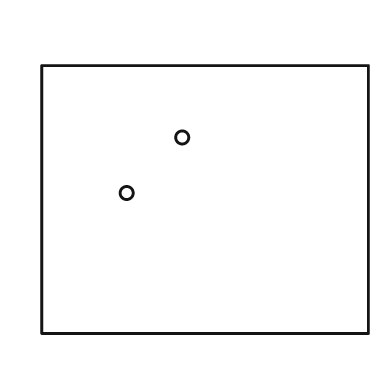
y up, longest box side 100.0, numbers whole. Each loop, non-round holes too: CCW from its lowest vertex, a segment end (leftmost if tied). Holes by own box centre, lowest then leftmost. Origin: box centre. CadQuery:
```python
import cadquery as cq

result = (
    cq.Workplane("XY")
    .moveTo(-50.0, -41.0)
    .lineTo(50.0, -41.0)
    .lineTo(50.0, 41.0)
    .lineTo(-50.0, 41.0)
    .close()
    .moveTo(-24.0, 2.0)
    .circle(2.0)
    .moveTo(-7.0, 19.0)
    .circle(2.0)
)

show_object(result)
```